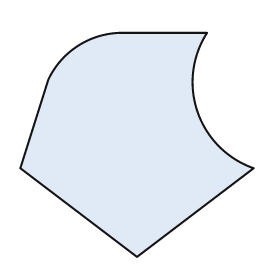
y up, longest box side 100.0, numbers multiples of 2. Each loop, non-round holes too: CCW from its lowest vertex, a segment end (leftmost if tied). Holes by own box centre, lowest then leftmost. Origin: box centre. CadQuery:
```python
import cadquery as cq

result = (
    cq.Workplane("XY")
    .moveTo(0.0, -48.0)
    .lineTo(50.0, -10.0)
    .threePointArc((26.0, 14.0), (30.0, 48.0))
    .lineTo(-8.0, 48.0)
    .threePointArc((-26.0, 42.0), (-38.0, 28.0))
    .lineTo(-50.0, -10.0)
    .close()
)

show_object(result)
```